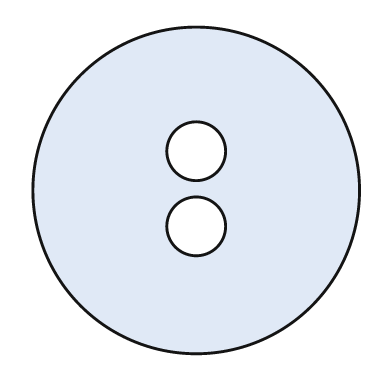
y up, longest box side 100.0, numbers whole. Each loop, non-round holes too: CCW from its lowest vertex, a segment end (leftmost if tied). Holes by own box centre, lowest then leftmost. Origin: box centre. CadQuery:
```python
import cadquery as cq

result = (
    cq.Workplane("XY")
    .moveTo(0.0, 0.0)
    .circle(50.0)
    .moveTo(0.0, -11.0)
    .circle(9.0)
    .moveTo(0.0, 12.0)
    .circle(9.0)
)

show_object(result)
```